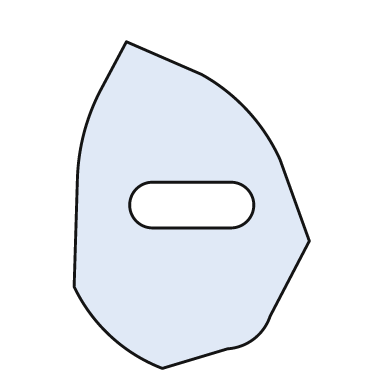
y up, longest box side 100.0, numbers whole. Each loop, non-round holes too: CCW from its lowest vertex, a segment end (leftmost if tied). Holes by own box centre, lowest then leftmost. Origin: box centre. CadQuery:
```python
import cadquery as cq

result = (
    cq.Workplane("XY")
    .moveTo(-9.0, -50.0)
    .lineTo(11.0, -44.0)
    .threePointArc((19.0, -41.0), (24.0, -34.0))
    .lineTo(36.0, -11.0)
    .lineTo(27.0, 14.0)
    .threePointArc((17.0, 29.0), (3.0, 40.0))
    .lineTo(-20.0, 50.0)
    .lineTo(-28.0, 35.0)
    .threePointArc((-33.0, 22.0), (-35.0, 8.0))
    .lineTo(-36.0, -25.0)
    .threePointArc((-25.0, -40.0), (-9.0, -50.0))
    .close()
    .moveTo(-12.0, -7.0)
    .lineTo(12.0, -7.0)
    .threePointArc((19.0, 0.0), (12.0, 7.0))
    .lineTo(-12.0, 7.0)
    .threePointArc((-19.0, 0.0), (-12.0, -7.0))
    .close()
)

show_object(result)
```